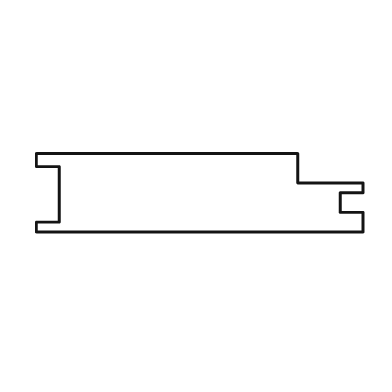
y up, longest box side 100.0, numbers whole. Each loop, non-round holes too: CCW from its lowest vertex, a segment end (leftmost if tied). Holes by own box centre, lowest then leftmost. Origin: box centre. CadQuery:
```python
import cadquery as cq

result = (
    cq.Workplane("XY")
    .moveTo(-50.0, -12.0)
    .lineTo(50.0, -12.0)
    .lineTo(50.0, -6.0)
    .lineTo(43.0, -6.0)
    .lineTo(43.0, 0.0)
    .lineTo(50.0, 0.0)
    .lineTo(50.0, 3.0)
    .lineTo(30.0, 3.0)
    .lineTo(30.0, 12.0)
    .lineTo(-50.0, 12.0)
    .lineTo(-50.0, 8.0)
    .lineTo(-43.0, 8.0)
    .lineTo(-43.0, -9.0)
    .lineTo(-50.0, -9.0)
    .close()
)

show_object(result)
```